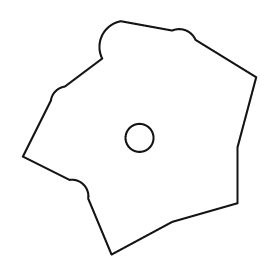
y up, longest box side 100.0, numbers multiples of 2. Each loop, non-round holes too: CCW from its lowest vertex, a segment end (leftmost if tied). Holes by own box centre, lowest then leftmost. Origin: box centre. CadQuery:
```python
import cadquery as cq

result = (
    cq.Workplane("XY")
    .moveTo(-12.0, -50.0)
    .lineTo(14.0, -36.0)
    .lineTo(42.0, -28.0)
    .lineTo(42.0, -4.0)
    .lineTo(50.0, 26.0)
    .lineTo(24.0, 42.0)
    .threePointArc((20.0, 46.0), (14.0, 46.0))
    .lineTo(-8.0, 50.0)
    .threePointArc((-16.0, 44.0), (-16.0, 34.0))
    .lineTo(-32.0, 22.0)
    .threePointArc((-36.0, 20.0), (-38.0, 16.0))
    .lineTo(-50.0, -8.0)
    .lineTo(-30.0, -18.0)
    .threePointArc((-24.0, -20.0), (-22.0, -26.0))
    .close()
    .moveTo(0.0, 0.0)
    .circle(6.0)
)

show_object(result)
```